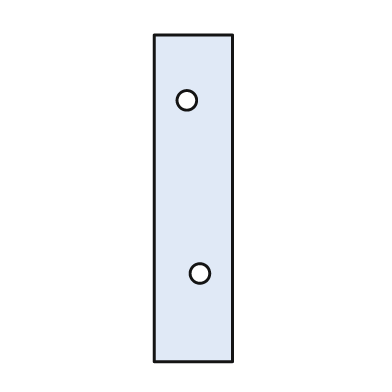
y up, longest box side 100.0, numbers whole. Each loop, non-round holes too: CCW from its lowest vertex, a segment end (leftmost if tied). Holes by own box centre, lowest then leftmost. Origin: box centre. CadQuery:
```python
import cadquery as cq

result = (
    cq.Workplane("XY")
    .moveTo(-12.0, -50.0)
    .lineTo(12.0, -50.0)
    .lineTo(12.0, 50.0)
    .lineTo(-12.0, 50.0)
    .close()
    .moveTo(2.0, -23.0)
    .circle(3.0)
    .moveTo(-2.0, 30.0)
    .circle(3.0)
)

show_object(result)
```